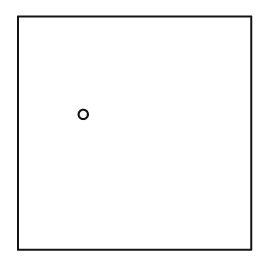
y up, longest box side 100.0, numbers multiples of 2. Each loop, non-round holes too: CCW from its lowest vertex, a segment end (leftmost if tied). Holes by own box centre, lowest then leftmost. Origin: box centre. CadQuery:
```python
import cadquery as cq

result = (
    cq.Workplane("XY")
    .moveTo(-50.0, -50.0)
    .lineTo(50.0, -50.0)
    .lineTo(50.0, 50.0)
    .lineTo(-50.0, 50.0)
    .close()
    .moveTo(-22.0, 8.0)
    .circle(2.0)
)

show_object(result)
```